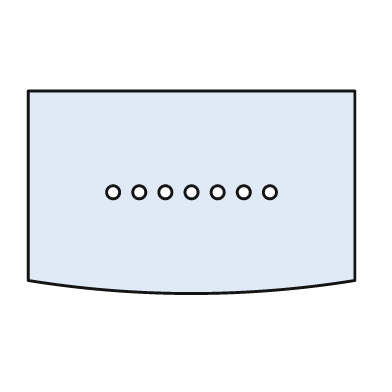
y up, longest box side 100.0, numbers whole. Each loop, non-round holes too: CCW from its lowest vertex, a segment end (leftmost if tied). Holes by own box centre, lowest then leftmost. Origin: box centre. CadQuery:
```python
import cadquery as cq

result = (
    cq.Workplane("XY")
    .moveTo(-50.0, -27.0)
    .threePointArc((0.0, -31.0), (50.0, -27.0))
    .lineTo(50.0, 31.0)
    .lineTo(-50.0, 31.0)
    .close()
    .moveTo(-24.0, 0.0)
    .circle(2.0)
    .moveTo(-16.0, 0.0)
    .circle(2.0)
    .moveTo(-8.0, 0.0)
    .circle(2.0)
    .moveTo(0.0, 0.0)
    .circle(2.0)
    .moveTo(8.0, 0.0)
    .circle(2.0)
    .moveTo(16.0, 0.0)
    .circle(2.0)
    .moveTo(24.0, 0.0)
    .circle(2.0)
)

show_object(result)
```